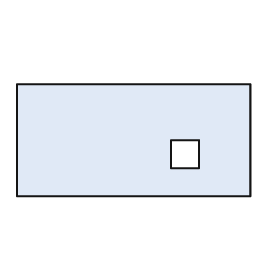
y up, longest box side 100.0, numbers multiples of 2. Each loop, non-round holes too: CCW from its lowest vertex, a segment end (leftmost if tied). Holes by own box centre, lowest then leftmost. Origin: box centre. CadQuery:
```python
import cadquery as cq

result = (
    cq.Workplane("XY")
    .moveTo(-50.0, -24.0)
    .lineTo(50.0, -24.0)
    .lineTo(50.0, 24.0)
    .lineTo(-50.0, 24.0)
    .close()
    .moveTo(16.0, -12.0)
    .lineTo(28.0, -12.0)
    .lineTo(28.0, 0.0)
    .lineTo(16.0, 0.0)
    .close()
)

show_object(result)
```